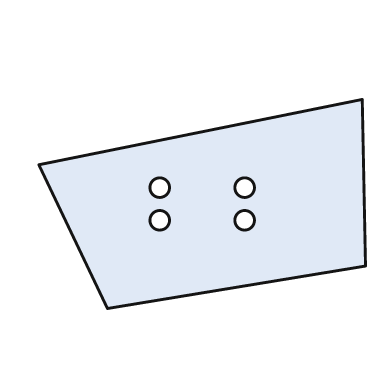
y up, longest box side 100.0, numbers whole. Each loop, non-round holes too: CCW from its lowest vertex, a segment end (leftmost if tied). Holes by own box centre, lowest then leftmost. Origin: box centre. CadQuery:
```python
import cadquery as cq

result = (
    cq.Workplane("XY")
    .moveTo(-29.0, -32.0)
    .lineTo(50.0, -19.0)
    .lineTo(49.0, 32.0)
    .lineTo(-50.0, 12.0)
    .close()
    .moveTo(-13.0, -5.0)
    .circle(3.0)
    .moveTo(13.0, -5.0)
    .circle(3.0)
    .moveTo(-13.0, 5.0)
    .circle(3.0)
    .moveTo(13.0, 5.0)
    .circle(3.0)
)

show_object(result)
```